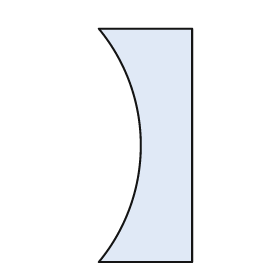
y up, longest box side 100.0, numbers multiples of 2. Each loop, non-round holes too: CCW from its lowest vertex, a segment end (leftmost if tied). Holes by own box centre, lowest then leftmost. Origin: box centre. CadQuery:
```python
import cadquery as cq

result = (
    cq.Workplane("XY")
    .moveTo(-20.0, -50.0)
    .lineTo(20.0, -50.0)
    .lineTo(20.0, 50.0)
    .lineTo(-20.0, 50.0)
    .threePointArc((-2.0, 0.0), (-20.0, -50.0))
    .close()
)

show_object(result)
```